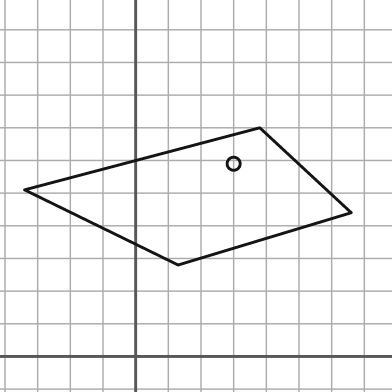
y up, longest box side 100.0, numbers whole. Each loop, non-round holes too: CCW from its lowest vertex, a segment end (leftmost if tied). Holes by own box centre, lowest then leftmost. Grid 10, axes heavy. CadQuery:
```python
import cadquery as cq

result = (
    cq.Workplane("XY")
    .moveTo(13.0, 28.0)
    .lineTo(66.0, 44.0)
    .lineTo(38.0, 70.0)
    .lineTo(-34.0, 51.0)
    .close()
    .moveTo(30.0, 59.0)
    .circle(2.0)
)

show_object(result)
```